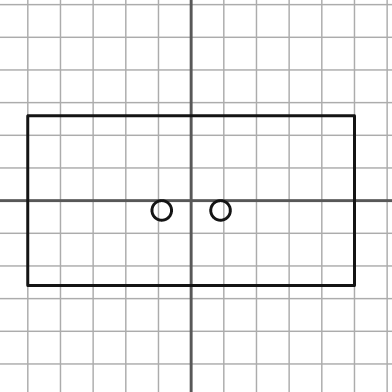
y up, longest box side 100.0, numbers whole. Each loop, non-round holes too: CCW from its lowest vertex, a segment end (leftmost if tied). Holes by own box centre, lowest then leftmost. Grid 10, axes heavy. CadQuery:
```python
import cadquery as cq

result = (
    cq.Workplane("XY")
    .moveTo(-50.0, -26.0)
    .lineTo(50.0, -26.0)
    .lineTo(50.0, 26.0)
    .lineTo(-50.0, 26.0)
    .close()
    .moveTo(-9.0, -3.0)
    .circle(3.0)
    .moveTo(9.0, -3.0)
    .circle(3.0)
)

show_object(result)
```